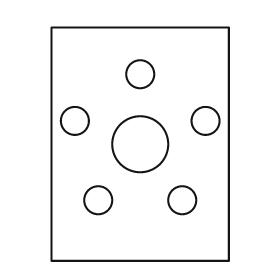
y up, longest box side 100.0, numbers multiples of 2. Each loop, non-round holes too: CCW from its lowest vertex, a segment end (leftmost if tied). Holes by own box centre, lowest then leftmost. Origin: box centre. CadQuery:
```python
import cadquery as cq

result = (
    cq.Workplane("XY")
    .moveTo(-38.0, -50.0)
    .lineTo(38.0, -50.0)
    .lineTo(38.0, 50.0)
    .lineTo(-38.0, 50.0)
    .close()
    .moveTo(-18.0, -24.0)
    .circle(6.0)
    .moveTo(18.0, -24.0)
    .circle(6.0)
    .moveTo(0.0, 0.0)
    .circle(12.0)
    .moveTo(-28.0, 10.0)
    .circle(6.0)
    .moveTo(28.0, 10.0)
    .circle(6.0)
    .moveTo(0.0, 30.0)
    .circle(6.0)
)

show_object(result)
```